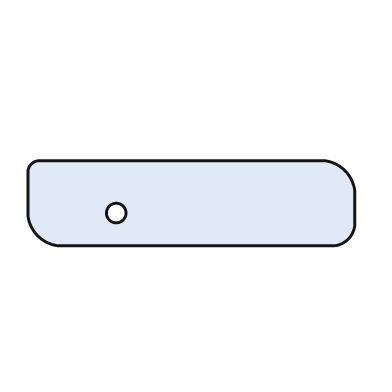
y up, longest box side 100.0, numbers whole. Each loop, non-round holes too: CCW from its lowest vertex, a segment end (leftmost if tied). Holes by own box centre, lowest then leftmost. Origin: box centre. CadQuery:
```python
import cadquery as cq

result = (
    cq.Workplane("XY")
    .moveTo(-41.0, -13.0)
    .lineTo(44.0, -13.0)
    .threePointArc((48.0, -11.0), (50.0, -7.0))
    .lineTo(50.0, 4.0)
    .threePointArc((47.0, 10.0), (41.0, 13.0))
    .lineTo(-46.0, 13.0)
    .threePointArc((-49.0, 12.0), (-50.0, 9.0))
    .lineTo(-50.0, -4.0)
    .threePointArc((-47.0, -10.0), (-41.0, -13.0))
    .close()
    .moveTo(-23.0, -3.0)
    .circle(3.0)
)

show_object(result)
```